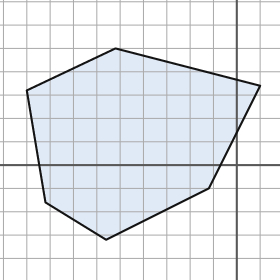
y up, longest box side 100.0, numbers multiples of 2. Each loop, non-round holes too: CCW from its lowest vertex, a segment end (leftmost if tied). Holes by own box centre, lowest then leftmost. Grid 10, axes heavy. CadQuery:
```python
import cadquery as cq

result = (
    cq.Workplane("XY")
    .moveTo(-56.0, -32.0)
    .lineTo(-12.0, -10.0)
    .lineTo(10.0, 34.0)
    .lineTo(-52.0, 50.0)
    .lineTo(-90.0, 32.0)
    .lineTo(-82.0, -16.0)
    .close()
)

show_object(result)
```